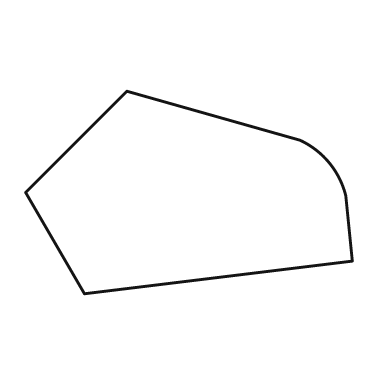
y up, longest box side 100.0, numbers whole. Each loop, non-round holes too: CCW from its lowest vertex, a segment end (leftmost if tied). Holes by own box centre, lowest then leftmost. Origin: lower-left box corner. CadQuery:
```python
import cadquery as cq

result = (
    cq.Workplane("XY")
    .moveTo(18.0, 0.0)
    .lineTo(100.0, 10.0)
    .lineTo(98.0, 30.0)
    .threePointArc((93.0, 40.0), (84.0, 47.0))
    .lineTo(31.0, 62.0)
    .lineTo(0.0, 31.0)
    .close()
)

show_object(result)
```